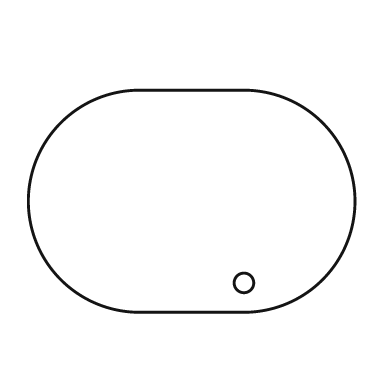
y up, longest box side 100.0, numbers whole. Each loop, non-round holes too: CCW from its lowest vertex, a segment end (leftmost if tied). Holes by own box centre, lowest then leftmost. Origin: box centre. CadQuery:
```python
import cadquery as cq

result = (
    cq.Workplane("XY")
    .moveTo(-16.0, -34.0)
    .lineTo(16.0, -34.0)
    .threePointArc((50.0, 0.0), (16.0, 34.0))
    .lineTo(-16.0, 34.0)
    .threePointArc((-50.0, 0.0), (-16.0, -34.0))
    .close()
    .moveTo(16.0, -25.0)
    .circle(3.0)
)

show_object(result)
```